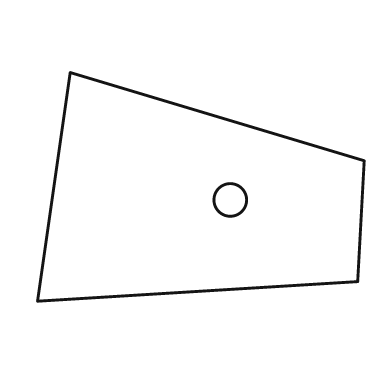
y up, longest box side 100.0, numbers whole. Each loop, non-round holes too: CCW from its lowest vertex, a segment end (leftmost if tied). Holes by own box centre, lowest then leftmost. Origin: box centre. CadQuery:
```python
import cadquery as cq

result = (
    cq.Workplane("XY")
    .moveTo(-50.0, -35.0)
    .lineTo(48.0, -29.0)
    .lineTo(50.0, 8.0)
    .lineTo(-40.0, 35.0)
    .close()
    .moveTo(9.0, -4.0)
    .circle(5.0)
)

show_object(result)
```